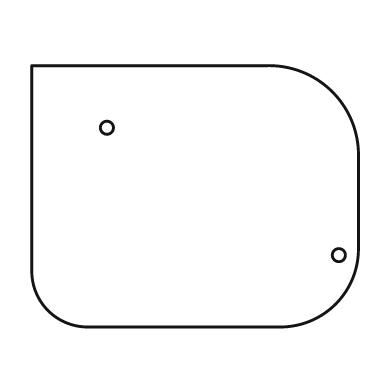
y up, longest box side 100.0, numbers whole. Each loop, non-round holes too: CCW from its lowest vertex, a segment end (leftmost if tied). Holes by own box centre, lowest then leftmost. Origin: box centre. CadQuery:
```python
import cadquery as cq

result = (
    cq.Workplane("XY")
    .moveTo(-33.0, -40.0)
    .lineTo(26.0, -40.0)
    .threePointArc((43.0, -33.0), (50.0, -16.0))
    .lineTo(50.0, 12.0)
    .threePointArc((42.0, 32.0), (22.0, 40.0))
    .lineTo(-50.0, 40.0)
    .lineTo(-50.0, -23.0)
    .threePointArc((-45.0, -35.0), (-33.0, -40.0))
    .close()
    .moveTo(44.0, -18.0)
    .circle(2.0)
    .moveTo(-27.0, 21.0)
    .circle(2.0)
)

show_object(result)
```